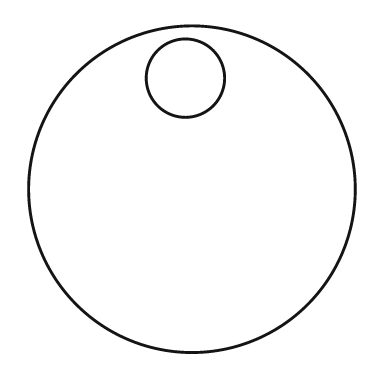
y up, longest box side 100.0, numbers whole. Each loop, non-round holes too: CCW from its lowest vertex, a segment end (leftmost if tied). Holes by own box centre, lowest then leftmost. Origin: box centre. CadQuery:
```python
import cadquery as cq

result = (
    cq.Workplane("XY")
    .moveTo(0.0, 0.0)
    .circle(50.0)
    .moveTo(-2.0, 34.0)
    .circle(12.0)
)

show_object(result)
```